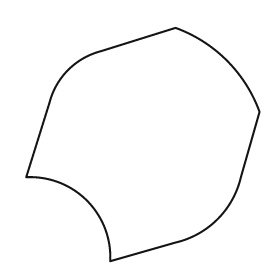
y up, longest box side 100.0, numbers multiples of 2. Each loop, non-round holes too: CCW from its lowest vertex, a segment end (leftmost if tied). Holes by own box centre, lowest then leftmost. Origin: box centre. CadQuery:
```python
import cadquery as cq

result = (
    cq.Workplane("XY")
    .moveTo(-14.0, -50.0)
    .lineTo(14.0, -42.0)
    .threePointArc((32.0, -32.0), (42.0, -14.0))
    .lineTo(50.0, 14.0)
    .threePointArc((36.0, 36.0), (14.0, 50.0))
    .lineTo(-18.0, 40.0)
    .threePointArc((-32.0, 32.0), (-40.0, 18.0))
    .lineTo(-50.0, -14.0)
    .threePointArc((-24.0, -24.0), (-14.0, -50.0))
    .close()
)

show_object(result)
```